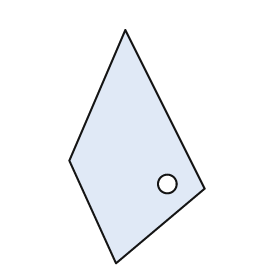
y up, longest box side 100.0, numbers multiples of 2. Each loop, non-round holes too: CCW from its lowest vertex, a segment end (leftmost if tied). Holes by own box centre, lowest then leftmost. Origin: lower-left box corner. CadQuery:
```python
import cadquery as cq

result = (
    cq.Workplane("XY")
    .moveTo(20.0, 0.0)
    .lineTo(58.0, 32.0)
    .lineTo(24.0, 100.0)
    .lineTo(0.0, 44.0)
    .close()
    .moveTo(42.0, 34.0)
    .circle(4.0)
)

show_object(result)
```